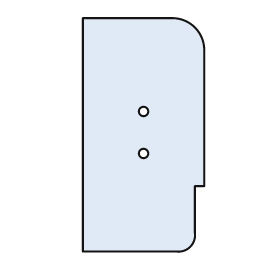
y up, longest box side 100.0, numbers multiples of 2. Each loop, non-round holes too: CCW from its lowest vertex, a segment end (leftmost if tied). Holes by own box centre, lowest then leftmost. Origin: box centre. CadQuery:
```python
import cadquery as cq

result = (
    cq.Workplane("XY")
    .moveTo(-26.0, -50.0)
    .lineTo(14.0, -50.0)
    .threePointArc((20.0, -48.0), (22.0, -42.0))
    .lineTo(22.0, -22.0)
    .lineTo(26.0, -22.0)
    .lineTo(26.0, 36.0)
    .threePointArc((22.0, 46.0), (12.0, 50.0))
    .lineTo(-26.0, 50.0)
    .close()
    .moveTo(0.0, -8.0)
    .circle(2.0)
    .moveTo(0.0, 10.0)
    .circle(2.0)
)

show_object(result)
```